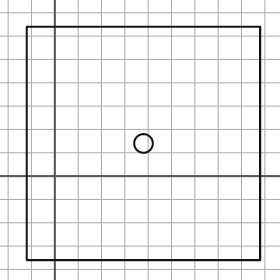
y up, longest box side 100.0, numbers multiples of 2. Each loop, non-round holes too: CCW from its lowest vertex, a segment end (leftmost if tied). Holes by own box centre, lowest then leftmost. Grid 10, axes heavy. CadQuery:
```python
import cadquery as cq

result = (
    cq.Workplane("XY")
    .moveTo(-12.0, -36.0)
    .lineTo(88.0, -36.0)
    .lineTo(88.0, 64.0)
    .lineTo(-12.0, 64.0)
    .close()
    .moveTo(38.0, 14.0)
    .circle(4.0)
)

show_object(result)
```